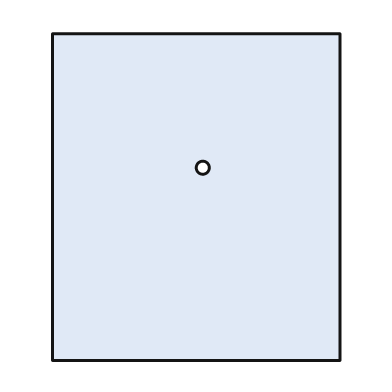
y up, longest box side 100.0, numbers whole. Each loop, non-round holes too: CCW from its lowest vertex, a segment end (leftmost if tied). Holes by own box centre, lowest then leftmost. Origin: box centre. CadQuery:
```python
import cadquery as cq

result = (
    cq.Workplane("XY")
    .moveTo(-44.0, -50.0)
    .lineTo(44.0, -50.0)
    .lineTo(44.0, 50.0)
    .lineTo(-44.0, 50.0)
    .close()
    .moveTo(2.0, 9.0)
    .circle(2.0)
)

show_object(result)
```